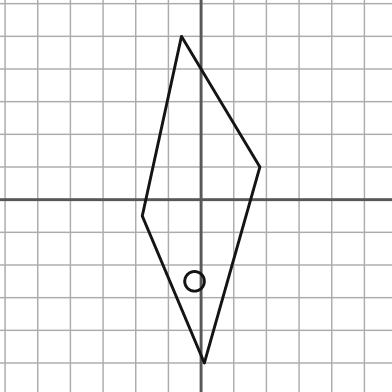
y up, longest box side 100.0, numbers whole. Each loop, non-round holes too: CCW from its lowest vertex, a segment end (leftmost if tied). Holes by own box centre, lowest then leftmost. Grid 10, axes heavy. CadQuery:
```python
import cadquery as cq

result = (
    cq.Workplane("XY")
    .moveTo(1.0, -50.0)
    .lineTo(18.0, 10.0)
    .lineTo(-6.0, 50.0)
    .lineTo(-18.0, -5.0)
    .close()
    .moveTo(-2.0, -25.0)
    .circle(3.0)
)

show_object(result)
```